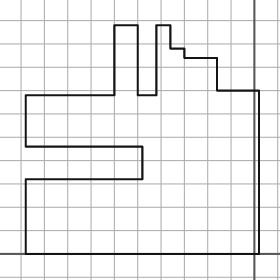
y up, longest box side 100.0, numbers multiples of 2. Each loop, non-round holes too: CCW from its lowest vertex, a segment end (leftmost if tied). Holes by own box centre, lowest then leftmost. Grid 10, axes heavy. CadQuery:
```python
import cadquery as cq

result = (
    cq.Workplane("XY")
    .moveTo(-98.0, 0.0)
    .lineTo(2.0, 0.0)
    .lineTo(2.0, 70.0)
    .lineTo(-16.0, 70.0)
    .lineTo(-16.0, 84.0)
    .lineTo(-30.0, 84.0)
    .lineTo(-30.0, 88.0)
    .lineTo(-36.0, 88.0)
    .lineTo(-36.0, 98.0)
    .lineTo(-42.0, 98.0)
    .lineTo(-42.0, 68.0)
    .lineTo(-50.0, 68.0)
    .lineTo(-50.0, 98.0)
    .lineTo(-60.0, 98.0)
    .lineTo(-60.0, 68.0)
    .lineTo(-98.0, 68.0)
    .lineTo(-98.0, 46.0)
    .lineTo(-48.0, 46.0)
    .lineTo(-48.0, 32.0)
    .lineTo(-98.0, 32.0)
    .close()
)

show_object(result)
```